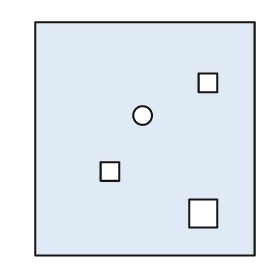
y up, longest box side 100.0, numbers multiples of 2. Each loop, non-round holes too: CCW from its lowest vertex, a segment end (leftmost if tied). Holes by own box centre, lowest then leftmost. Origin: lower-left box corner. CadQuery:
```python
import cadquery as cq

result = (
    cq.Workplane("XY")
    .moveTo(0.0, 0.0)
    .lineTo(94.0, 0.0)
    .lineTo(94.0, 100.0)
    .lineTo(0.0, 100.0)
    .close()
    .moveTo(66.0, 12.0)
    .lineTo(78.0, 12.0)
    .lineTo(78.0, 24.0)
    .lineTo(66.0, 24.0)
    .close()
    .moveTo(28.0, 32.0)
    .lineTo(36.0, 32.0)
    .lineTo(36.0, 40.0)
    .lineTo(28.0, 40.0)
    .close()
    .moveTo(46.0, 60.0)
    .circle(4.0)
    .moveTo(70.0, 70.0)
    .lineTo(78.0, 70.0)
    .lineTo(78.0, 78.0)
    .lineTo(70.0, 78.0)
    .close()
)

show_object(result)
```